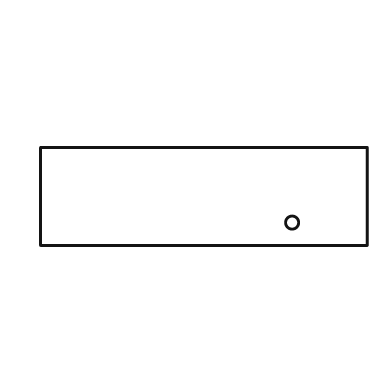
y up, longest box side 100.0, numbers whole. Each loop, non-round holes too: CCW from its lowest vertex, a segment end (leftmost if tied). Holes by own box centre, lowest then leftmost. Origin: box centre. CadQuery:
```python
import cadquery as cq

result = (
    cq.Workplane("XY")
    .moveTo(-50.0, -15.0)
    .lineTo(50.0, -15.0)
    .lineTo(50.0, 15.0)
    .lineTo(-50.0, 15.0)
    .close()
    .moveTo(27.0, -8.0)
    .circle(2.0)
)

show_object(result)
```